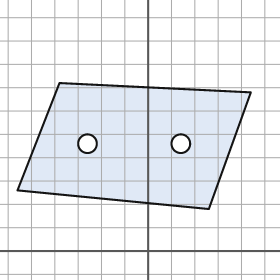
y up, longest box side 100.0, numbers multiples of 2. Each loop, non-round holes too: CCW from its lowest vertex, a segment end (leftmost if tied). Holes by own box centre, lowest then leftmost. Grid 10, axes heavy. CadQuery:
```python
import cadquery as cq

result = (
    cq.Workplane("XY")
    .moveTo(26.0, 18.0)
    .lineTo(44.0, 68.0)
    .lineTo(-38.0, 72.0)
    .lineTo(-56.0, 26.0)
    .close()
    .moveTo(-26.0, 46.0)
    .circle(4.0)
    .moveTo(14.0, 46.0)
    .circle(4.0)
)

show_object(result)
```